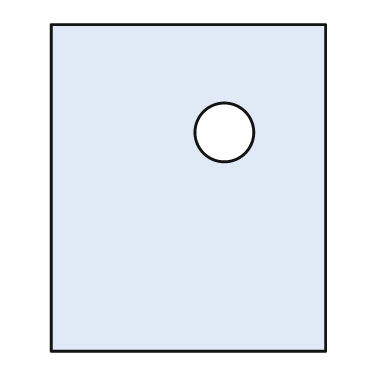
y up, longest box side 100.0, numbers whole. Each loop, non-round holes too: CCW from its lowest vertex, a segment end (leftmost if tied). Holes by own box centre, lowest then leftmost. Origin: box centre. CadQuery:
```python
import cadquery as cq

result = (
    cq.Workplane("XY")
    .moveTo(-42.0, -50.0)
    .lineTo(42.0, -50.0)
    .lineTo(42.0, 50.0)
    .lineTo(-42.0, 50.0)
    .close()
    .moveTo(11.0, 17.0)
    .circle(9.0)
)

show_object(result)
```